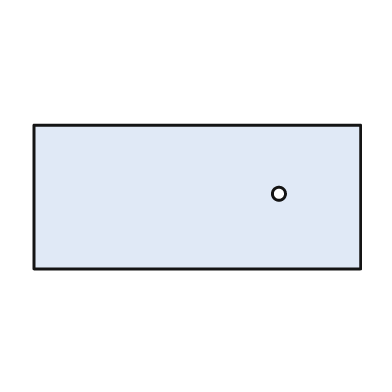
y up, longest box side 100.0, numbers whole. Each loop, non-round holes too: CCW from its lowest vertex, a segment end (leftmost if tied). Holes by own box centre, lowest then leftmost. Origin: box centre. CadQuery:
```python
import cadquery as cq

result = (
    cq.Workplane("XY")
    .moveTo(-50.0, -22.0)
    .lineTo(50.0, -22.0)
    .lineTo(50.0, 22.0)
    .lineTo(-50.0, 22.0)
    .close()
    .moveTo(25.0, 1.0)
    .circle(2.0)
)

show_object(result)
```